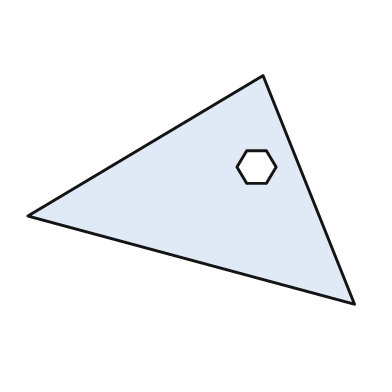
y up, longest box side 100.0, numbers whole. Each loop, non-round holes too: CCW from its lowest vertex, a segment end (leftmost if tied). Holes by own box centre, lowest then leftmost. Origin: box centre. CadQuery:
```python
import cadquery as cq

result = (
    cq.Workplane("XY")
    .moveTo(50.0, -35.0)
    .lineTo(22.0, 35.0)
    .lineTo(-50.0, -8.0)
    .close()
    .moveTo(17.0, 2.0)
    .lineTo(23.0, 2.0)
    .lineTo(26.0, 7.0)
    .lineTo(23.0, 12.0)
    .lineTo(17.0, 12.0)
    .lineTo(14.0, 7.0)
    .close()
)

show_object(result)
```